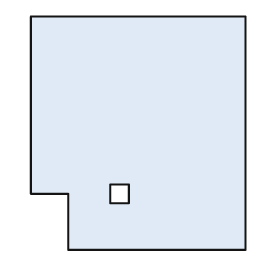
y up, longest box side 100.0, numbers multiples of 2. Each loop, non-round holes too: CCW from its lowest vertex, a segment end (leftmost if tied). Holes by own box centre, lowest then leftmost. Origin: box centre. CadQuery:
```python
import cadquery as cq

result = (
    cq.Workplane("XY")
    .moveTo(-30.0, -50.0)
    .lineTo(46.0, -50.0)
    .lineTo(46.0, 50.0)
    .lineTo(-46.0, 50.0)
    .lineTo(-46.0, -26.0)
    .lineTo(-30.0, -26.0)
    .close()
    .moveTo(-12.0, -30.0)
    .lineTo(-4.0, -30.0)
    .lineTo(-4.0, -22.0)
    .lineTo(-12.0, -22.0)
    .close()
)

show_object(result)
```